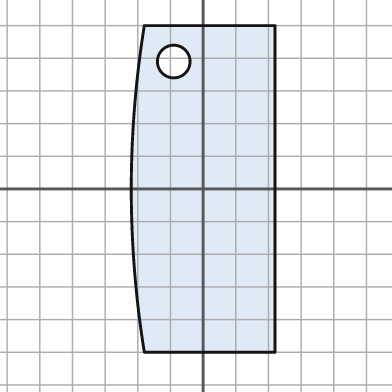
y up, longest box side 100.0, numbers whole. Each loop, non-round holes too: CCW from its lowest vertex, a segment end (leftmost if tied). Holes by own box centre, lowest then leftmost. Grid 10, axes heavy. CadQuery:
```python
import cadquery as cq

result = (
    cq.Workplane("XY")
    .moveTo(-18.0, -50.0)
    .lineTo(22.0, -50.0)
    .lineTo(22.0, 50.0)
    .lineTo(-18.0, 50.0)
    .threePointArc((-22.0, 0.0), (-18.0, -50.0))
    .close()
    .moveTo(-9.0, 39.0)
    .circle(5.0)
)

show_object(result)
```